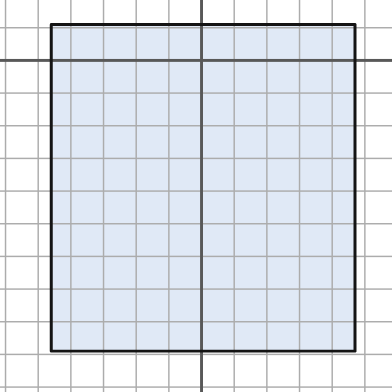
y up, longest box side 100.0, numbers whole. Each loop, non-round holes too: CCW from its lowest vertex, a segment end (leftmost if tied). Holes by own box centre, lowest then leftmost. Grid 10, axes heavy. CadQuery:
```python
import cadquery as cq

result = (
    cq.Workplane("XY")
    .moveTo(-46.0, -89.0)
    .lineTo(47.0, -89.0)
    .lineTo(47.0, 11.0)
    .lineTo(-46.0, 11.0)
    .close()
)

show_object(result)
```